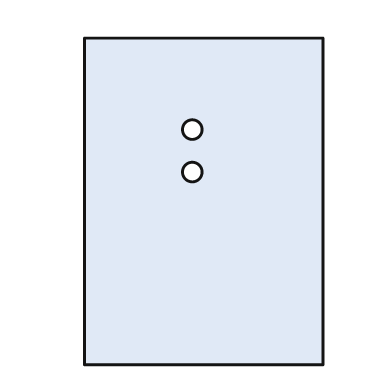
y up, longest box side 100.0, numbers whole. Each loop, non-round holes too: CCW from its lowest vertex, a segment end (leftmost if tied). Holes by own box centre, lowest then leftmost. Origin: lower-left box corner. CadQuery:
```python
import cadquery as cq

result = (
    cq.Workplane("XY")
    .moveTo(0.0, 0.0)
    .lineTo(73.0, 0.0)
    .lineTo(73.0, 100.0)
    .lineTo(0.0, 100.0)
    .close()
    .moveTo(33.0, 59.0)
    .circle(3.0)
    .moveTo(33.0, 72.0)
    .circle(3.0)
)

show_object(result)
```